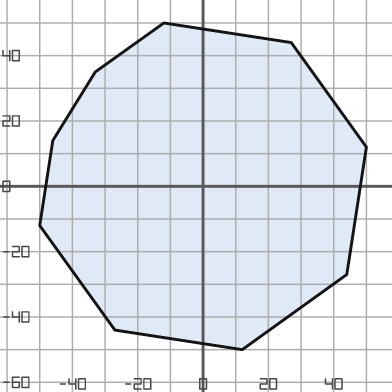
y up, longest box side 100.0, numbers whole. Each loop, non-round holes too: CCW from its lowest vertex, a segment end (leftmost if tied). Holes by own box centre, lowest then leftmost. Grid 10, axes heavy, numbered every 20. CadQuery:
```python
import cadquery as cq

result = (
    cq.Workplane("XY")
    .moveTo(12.0, -50.0)
    .lineTo(44.0, -27.0)
    .lineTo(50.0, 12.0)
    .lineTo(27.0, 44.0)
    .lineTo(-12.0, 50.0)
    .lineTo(-33.0, 35.0)
    .lineTo(-46.0, 14.0)
    .lineTo(-50.0, -12.0)
    .lineTo(-27.0, -44.0)
    .close()
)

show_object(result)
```